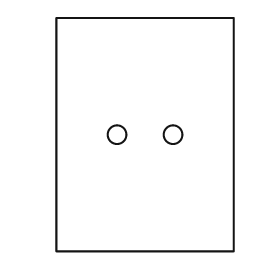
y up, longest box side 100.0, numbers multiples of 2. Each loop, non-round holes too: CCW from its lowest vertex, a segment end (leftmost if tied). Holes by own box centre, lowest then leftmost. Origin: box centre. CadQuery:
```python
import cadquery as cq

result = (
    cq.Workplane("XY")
    .moveTo(-38.0, -50.0)
    .lineTo(38.0, -50.0)
    .lineTo(38.0, 50.0)
    .lineTo(-38.0, 50.0)
    .close()
    .moveTo(-12.0, 0.0)
    .circle(4.0)
    .moveTo(12.0, 0.0)
    .circle(4.0)
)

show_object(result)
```